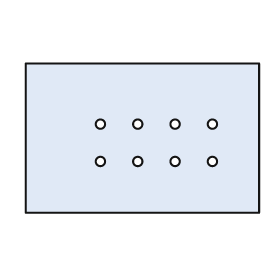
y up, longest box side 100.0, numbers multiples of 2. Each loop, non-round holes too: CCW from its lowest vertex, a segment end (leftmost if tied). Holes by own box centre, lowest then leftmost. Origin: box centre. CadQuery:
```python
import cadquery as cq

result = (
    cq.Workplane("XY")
    .moveTo(-50.0, -32.0)
    .lineTo(50.0, -32.0)
    .lineTo(50.0, 32.0)
    .lineTo(-50.0, 32.0)
    .close()
    .moveTo(-18.0, -10.0)
    .circle(2.0)
    .moveTo(-2.0, -10.0)
    .circle(2.0)
    .moveTo(14.0, -10.0)
    .circle(2.0)
    .moveTo(30.0, -10.0)
    .circle(2.0)
    .moveTo(-18.0, 6.0)
    .circle(2.0)
    .moveTo(-2.0, 6.0)
    .circle(2.0)
    .moveTo(14.0, 6.0)
    .circle(2.0)
    .moveTo(30.0, 6.0)
    .circle(2.0)
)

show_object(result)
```